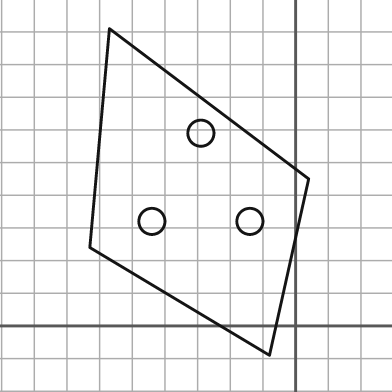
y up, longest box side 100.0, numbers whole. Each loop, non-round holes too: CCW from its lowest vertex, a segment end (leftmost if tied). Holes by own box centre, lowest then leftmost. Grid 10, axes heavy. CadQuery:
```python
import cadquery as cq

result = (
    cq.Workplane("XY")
    .moveTo(-8.0, -9.0)
    .lineTo(4.0, 45.0)
    .lineTo(-57.0, 91.0)
    .lineTo(-63.0, 24.0)
    .close()
    .moveTo(-44.0, 32.0)
    .circle(4.0)
    .moveTo(-14.0, 32.0)
    .circle(4.0)
    .moveTo(-29.0, 59.0)
    .circle(4.0)
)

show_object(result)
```